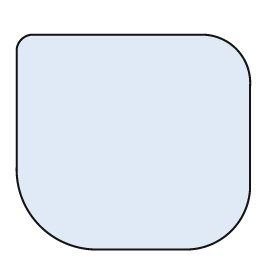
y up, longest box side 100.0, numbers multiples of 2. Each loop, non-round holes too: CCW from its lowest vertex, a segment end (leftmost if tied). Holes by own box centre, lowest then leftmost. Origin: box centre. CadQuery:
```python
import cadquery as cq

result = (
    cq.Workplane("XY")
    .moveTo(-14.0, -46.0)
    .lineTo(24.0, -46.0)
    .threePointArc((42.0, -38.0), (50.0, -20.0))
    .lineTo(50.0, 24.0)
    .threePointArc((44.0, 40.0), (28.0, 46.0))
    .lineTo(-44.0, 46.0)
    .threePointArc((-48.0, 44.0), (-50.0, 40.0))
    .lineTo(-50.0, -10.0)
    .threePointArc((-40.0, -36.0), (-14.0, -46.0))
    .close()
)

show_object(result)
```